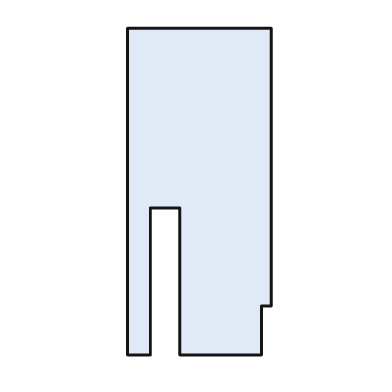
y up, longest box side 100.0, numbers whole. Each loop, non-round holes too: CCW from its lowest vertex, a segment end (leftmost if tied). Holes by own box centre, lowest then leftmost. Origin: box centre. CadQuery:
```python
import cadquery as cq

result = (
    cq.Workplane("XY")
    .moveTo(-22.0, -50.0)
    .lineTo(-15.0, -50.0)
    .lineTo(-15.0, -5.0)
    .lineTo(-6.0, -5.0)
    .lineTo(-6.0, -50.0)
    .lineTo(19.0, -50.0)
    .lineTo(19.0, -35.0)
    .lineTo(22.0, -35.0)
    .lineTo(22.0, 50.0)
    .lineTo(-22.0, 50.0)
    .close()
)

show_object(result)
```